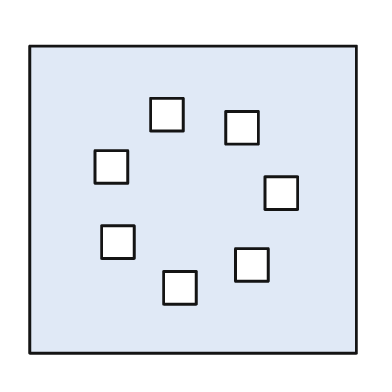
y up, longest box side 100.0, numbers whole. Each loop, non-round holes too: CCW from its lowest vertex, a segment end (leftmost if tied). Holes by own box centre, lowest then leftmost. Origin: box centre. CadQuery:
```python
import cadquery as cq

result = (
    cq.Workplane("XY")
    .moveTo(-50.0, -47.0)
    .lineTo(50.0, -47.0)
    .lineTo(50.0, 47.0)
    .lineTo(-50.0, 47.0)
    .close()
    .moveTo(-9.0, -32.0)
    .lineTo(1.0, -32.0)
    .lineTo(1.0, -22.0)
    .lineTo(-9.0, -22.0)
    .close()
    .moveTo(13.0, -25.0)
    .lineTo(23.0, -25.0)
    .lineTo(23.0, -15.0)
    .lineTo(13.0, -15.0)
    .close()
    .moveTo(-28.0, -18.0)
    .lineTo(-18.0, -18.0)
    .lineTo(-18.0, -8.0)
    .lineTo(-28.0, -8.0)
    .close()
    .moveTo(22.0, -3.0)
    .lineTo(32.0, -3.0)
    .lineTo(32.0, 7.0)
    .lineTo(22.0, 7.0)
    .close()
    .moveTo(-30.0, 5.0)
    .lineTo(-20.0, 5.0)
    .lineTo(-20.0, 15.0)
    .lineTo(-30.0, 15.0)
    .close()
    .moveTo(10.0, 17.0)
    .lineTo(20.0, 17.0)
    .lineTo(20.0, 27.0)
    .lineTo(10.0, 27.0)
    .close()
    .moveTo(-13.0, 21.0)
    .lineTo(-3.0, 21.0)
    .lineTo(-3.0, 31.0)
    .lineTo(-13.0, 31.0)
    .close()
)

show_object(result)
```